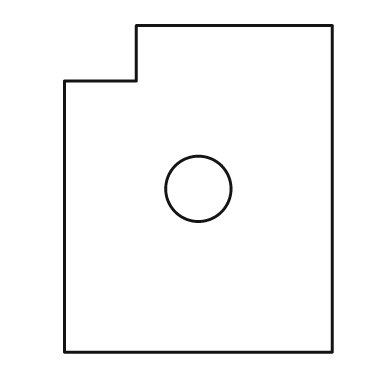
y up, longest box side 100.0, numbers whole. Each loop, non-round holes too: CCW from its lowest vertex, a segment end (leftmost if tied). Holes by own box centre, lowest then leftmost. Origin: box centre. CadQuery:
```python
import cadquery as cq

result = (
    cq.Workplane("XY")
    .moveTo(-41.0, -50.0)
    .lineTo(41.0, -50.0)
    .lineTo(41.0, 50.0)
    .lineTo(-19.0, 50.0)
    .lineTo(-19.0, 33.0)
    .lineTo(-41.0, 33.0)
    .close()
    .moveTo(0.0, 0.0)
    .circle(10.0)
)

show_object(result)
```